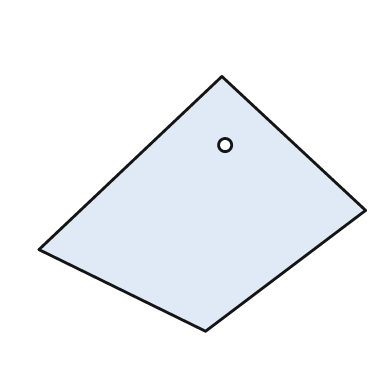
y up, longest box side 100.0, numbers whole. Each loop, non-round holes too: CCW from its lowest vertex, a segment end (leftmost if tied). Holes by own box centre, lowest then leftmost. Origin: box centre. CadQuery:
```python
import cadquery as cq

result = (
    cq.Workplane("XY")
    .moveTo(1.0, -39.0)
    .lineTo(50.0, -2.0)
    .lineTo(6.0, 39.0)
    .lineTo(-50.0, -14.0)
    .close()
    .moveTo(7.0, 18.0)
    .circle(2.0)
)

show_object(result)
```